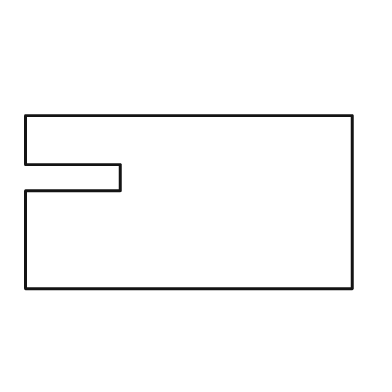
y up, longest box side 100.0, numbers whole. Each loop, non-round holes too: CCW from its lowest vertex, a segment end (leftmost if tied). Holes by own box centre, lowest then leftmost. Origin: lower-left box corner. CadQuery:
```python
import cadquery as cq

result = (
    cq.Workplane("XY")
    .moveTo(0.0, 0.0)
    .lineTo(100.0, 0.0)
    .lineTo(100.0, 53.0)
    .lineTo(0.0, 53.0)
    .lineTo(0.0, 38.0)
    .lineTo(29.0, 38.0)
    .lineTo(29.0, 30.0)
    .lineTo(0.0, 30.0)
    .close()
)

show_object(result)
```